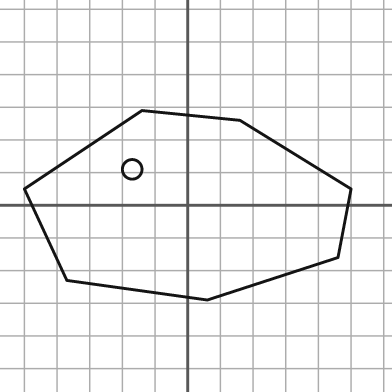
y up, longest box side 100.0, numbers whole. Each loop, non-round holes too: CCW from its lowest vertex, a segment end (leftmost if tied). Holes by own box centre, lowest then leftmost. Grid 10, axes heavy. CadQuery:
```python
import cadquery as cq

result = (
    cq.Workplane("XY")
    .moveTo(6.0, -29.0)
    .lineTo(46.0, -16.0)
    .lineTo(50.0, 5.0)
    .lineTo(16.0, 26.0)
    .lineTo(-14.0, 29.0)
    .lineTo(-50.0, 5.0)
    .lineTo(-37.0, -23.0)
    .close()
    .moveTo(-17.0, 11.0)
    .circle(3.0)
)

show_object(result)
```